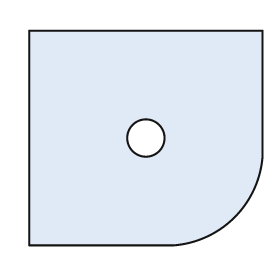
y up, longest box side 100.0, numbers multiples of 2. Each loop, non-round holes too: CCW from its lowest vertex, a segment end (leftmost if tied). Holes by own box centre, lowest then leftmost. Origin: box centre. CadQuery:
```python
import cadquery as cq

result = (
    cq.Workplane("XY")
    .moveTo(-50.0, -46.0)
    .lineTo(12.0, -46.0)
    .threePointArc((38.0, -34.0), (50.0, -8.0))
    .lineTo(50.0, 46.0)
    .lineTo(-50.0, 46.0)
    .close()
    .moveTo(0.0, 0.0)
    .circle(8.0)
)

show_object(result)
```